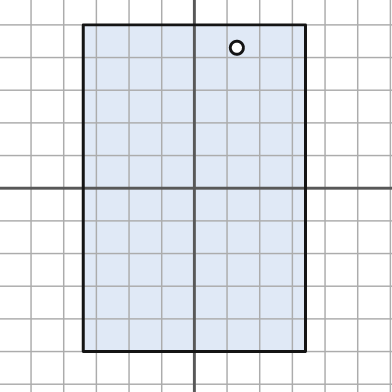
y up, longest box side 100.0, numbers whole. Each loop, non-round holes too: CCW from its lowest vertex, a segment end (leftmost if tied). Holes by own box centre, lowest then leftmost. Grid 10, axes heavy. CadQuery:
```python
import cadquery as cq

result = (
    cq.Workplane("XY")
    .moveTo(-34.0, -50.0)
    .lineTo(34.0, -50.0)
    .lineTo(34.0, 50.0)
    .lineTo(-34.0, 50.0)
    .close()
    .moveTo(13.0, 43.0)
    .circle(2.0)
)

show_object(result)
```